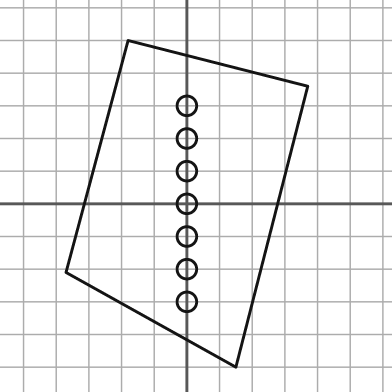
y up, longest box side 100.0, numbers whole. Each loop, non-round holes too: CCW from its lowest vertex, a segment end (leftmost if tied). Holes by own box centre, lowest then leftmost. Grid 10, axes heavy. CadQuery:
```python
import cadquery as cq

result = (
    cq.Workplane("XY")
    .moveTo(15.0, -50.0)
    .lineTo(37.0, 36.0)
    .lineTo(-18.0, 50.0)
    .lineTo(-37.0, -21.0)
    .close()
    .moveTo(0.0, -30.0)
    .circle(3.0)
    .moveTo(0.0, -20.0)
    .circle(3.0)
    .moveTo(0.0, -10.0)
    .circle(3.0)
    .moveTo(0.0, 0.0)
    .circle(3.0)
    .moveTo(0.0, 10.0)
    .circle(3.0)
    .moveTo(0.0, 20.0)
    .circle(3.0)
    .moveTo(0.0, 30.0)
    .circle(3.0)
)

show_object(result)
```